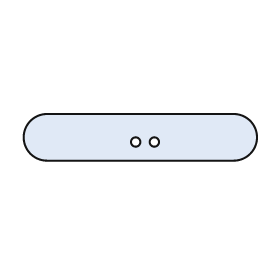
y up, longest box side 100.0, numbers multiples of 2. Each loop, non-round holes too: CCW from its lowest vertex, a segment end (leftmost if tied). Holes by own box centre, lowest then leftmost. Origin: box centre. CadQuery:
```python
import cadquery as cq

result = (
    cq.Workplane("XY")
    .moveTo(-40.0, -10.0)
    .lineTo(40.0, -10.0)
    .threePointArc((50.0, 0.0), (40.0, 10.0))
    .lineTo(-40.0, 10.0)
    .threePointArc((-50.0, 0.0), (-40.0, -10.0))
    .close()
    .moveTo(-2.0, -2.0)
    .circle(2.0)
    .moveTo(6.0, -2.0)
    .circle(2.0)
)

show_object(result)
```